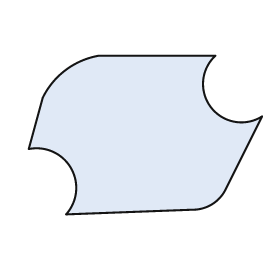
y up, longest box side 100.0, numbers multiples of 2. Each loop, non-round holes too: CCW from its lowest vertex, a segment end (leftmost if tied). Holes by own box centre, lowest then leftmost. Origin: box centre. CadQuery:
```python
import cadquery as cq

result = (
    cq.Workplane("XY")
    .moveTo(-34.0, -34.0)
    .lineTo(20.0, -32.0)
    .threePointArc((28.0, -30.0), (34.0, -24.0))
    .lineTo(50.0, 8.0)
    .threePointArc((28.0, 12.0), (30.0, 34.0))
    .lineTo(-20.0, 34.0)
    .threePointArc((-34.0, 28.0), (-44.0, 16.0))
    .lineTo(-50.0, -6.0)
    .threePointArc((-32.0, -14.0), (-34.0, -34.0))
    .close()
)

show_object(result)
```